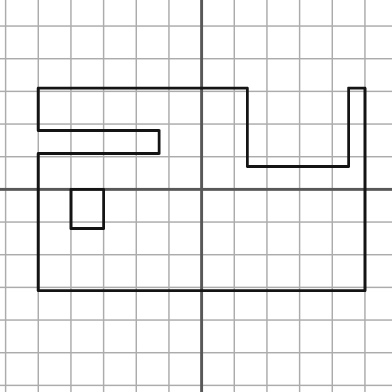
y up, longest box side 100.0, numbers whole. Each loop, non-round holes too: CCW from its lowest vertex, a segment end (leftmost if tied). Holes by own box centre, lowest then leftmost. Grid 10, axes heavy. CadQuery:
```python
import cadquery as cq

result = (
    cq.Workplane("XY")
    .moveTo(-50.0, -31.0)
    .lineTo(50.0, -31.0)
    .lineTo(50.0, 31.0)
    .lineTo(45.0, 31.0)
    .lineTo(45.0, 7.0)
    .lineTo(14.0, 7.0)
    .lineTo(14.0, 31.0)
    .lineTo(-50.0, 31.0)
    .lineTo(-50.0, 18.0)
    .lineTo(-13.0, 18.0)
    .lineTo(-13.0, 11.0)
    .lineTo(-50.0, 11.0)
    .close()
    .moveTo(-40.0, -12.0)
    .lineTo(-30.0, -12.0)
    .lineTo(-30.0, 0.0)
    .lineTo(-40.0, 0.0)
    .close()
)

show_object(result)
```